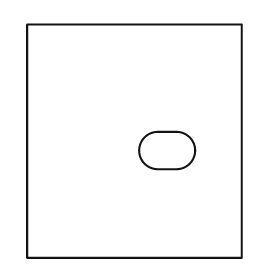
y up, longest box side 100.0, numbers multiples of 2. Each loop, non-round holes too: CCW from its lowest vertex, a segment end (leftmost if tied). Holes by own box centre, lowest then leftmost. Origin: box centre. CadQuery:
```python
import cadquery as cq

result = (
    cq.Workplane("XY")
    .moveTo(-46.0, -50.0)
    .lineTo(46.0, -50.0)
    .lineTo(46.0, 50.0)
    .lineTo(-46.0, 50.0)
    .close()
    .moveTo(10.0, -12.0)
    .lineTo(18.0, -12.0)
    .threePointArc((26.0, -4.0), (18.0, 4.0))
    .lineTo(10.0, 4.0)
    .threePointArc((2.0, -4.0), (10.0, -12.0))
    .close()
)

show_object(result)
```